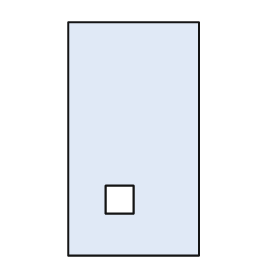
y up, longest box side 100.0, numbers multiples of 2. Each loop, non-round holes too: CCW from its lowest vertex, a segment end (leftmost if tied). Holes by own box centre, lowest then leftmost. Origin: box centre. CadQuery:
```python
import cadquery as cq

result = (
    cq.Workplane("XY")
    .moveTo(-28.0, -50.0)
    .lineTo(28.0, -50.0)
    .lineTo(28.0, 50.0)
    .lineTo(-28.0, 50.0)
    .close()
    .moveTo(-12.0, -32.0)
    .lineTo(0.0, -32.0)
    .lineTo(0.0, -20.0)
    .lineTo(-12.0, -20.0)
    .close()
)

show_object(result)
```